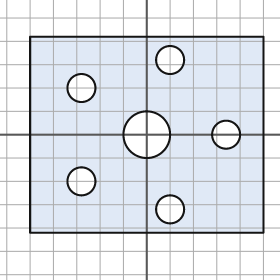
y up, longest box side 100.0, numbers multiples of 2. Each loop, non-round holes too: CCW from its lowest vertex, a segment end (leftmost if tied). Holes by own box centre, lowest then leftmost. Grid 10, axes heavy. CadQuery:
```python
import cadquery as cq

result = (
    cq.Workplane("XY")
    .moveTo(-50.0, -42.0)
    .lineTo(50.0, -42.0)
    .lineTo(50.0, 42.0)
    .lineTo(-50.0, 42.0)
    .close()
    .moveTo(10.0, -32.0)
    .circle(6.0)
    .moveTo(-28.0, -20.0)
    .circle(6.0)
    .moveTo(0.0, 0.0)
    .circle(10.0)
    .moveTo(34.0, 0.0)
    .circle(6.0)
    .moveTo(-28.0, 20.0)
    .circle(6.0)
    .moveTo(10.0, 32.0)
    .circle(6.0)
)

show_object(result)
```